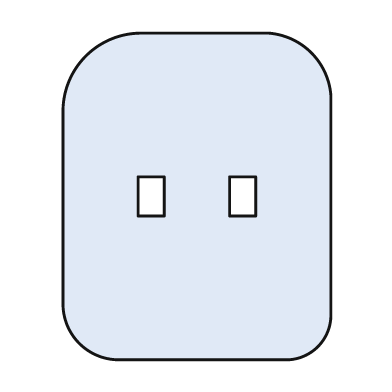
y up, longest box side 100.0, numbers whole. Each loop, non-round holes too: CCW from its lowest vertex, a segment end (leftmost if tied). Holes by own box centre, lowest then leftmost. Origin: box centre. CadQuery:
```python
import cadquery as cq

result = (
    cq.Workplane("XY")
    .moveTo(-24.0, -50.0)
    .lineTo(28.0, -50.0)
    .threePointArc((37.0, -46.0), (41.0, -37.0))
    .lineTo(41.0, 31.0)
    .threePointArc((35.0, 44.0), (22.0, 50.0))
    .lineTo(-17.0, 50.0)
    .threePointArc((-34.0, 43.0), (-41.0, 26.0))
    .lineTo(-41.0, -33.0)
    .threePointArc((-36.0, -45.0), (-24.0, -50.0))
    .close()
    .moveTo(-18.0, -6.0)
    .lineTo(-10.0, -6.0)
    .lineTo(-10.0, 6.0)
    .lineTo(-18.0, 6.0)
    .close()
    .moveTo(10.0, -6.0)
    .lineTo(18.0, -6.0)
    .lineTo(18.0, 6.0)
    .lineTo(10.0, 6.0)
    .close()
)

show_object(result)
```